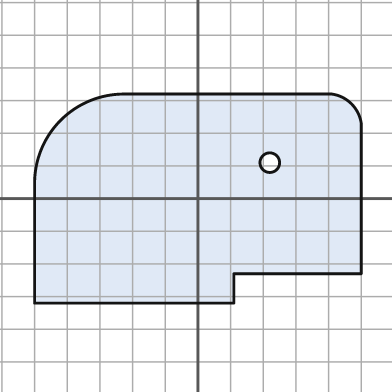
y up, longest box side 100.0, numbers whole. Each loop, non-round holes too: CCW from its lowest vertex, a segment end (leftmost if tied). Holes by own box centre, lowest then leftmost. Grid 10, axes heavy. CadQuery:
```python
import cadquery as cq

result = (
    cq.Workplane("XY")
    .moveTo(-50.0, -32.0)
    .lineTo(11.0, -32.0)
    .lineTo(11.0, -23.0)
    .lineTo(50.0, -23.0)
    .lineTo(50.0, 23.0)
    .threePointArc((47.0, 29.0), (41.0, 32.0))
    .lineTo(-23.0, 32.0)
    .threePointArc((-42.0, 24.0), (-50.0, 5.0))
    .close()
    .moveTo(22.0, 11.0)
    .circle(3.0)
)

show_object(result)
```